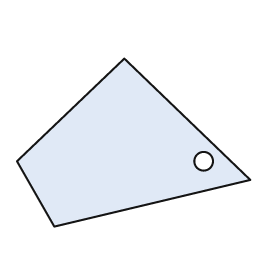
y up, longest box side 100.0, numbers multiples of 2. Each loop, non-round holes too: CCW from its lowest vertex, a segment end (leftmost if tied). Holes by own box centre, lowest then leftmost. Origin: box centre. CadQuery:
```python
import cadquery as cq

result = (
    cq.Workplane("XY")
    .moveTo(-34.0, -36.0)
    .lineTo(50.0, -16.0)
    .lineTo(-4.0, 36.0)
    .lineTo(-50.0, -8.0)
    .close()
    .moveTo(30.0, -8.0)
    .circle(4.0)
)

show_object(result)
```